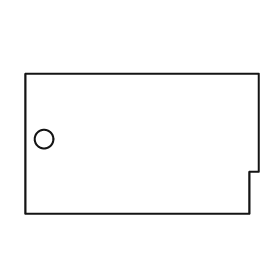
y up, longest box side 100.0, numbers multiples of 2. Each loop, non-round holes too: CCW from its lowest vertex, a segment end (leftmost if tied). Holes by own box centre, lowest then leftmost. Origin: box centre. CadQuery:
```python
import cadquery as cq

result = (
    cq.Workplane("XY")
    .moveTo(-50.0, -30.0)
    .lineTo(46.0, -30.0)
    .lineTo(46.0, -12.0)
    .lineTo(50.0, -12.0)
    .lineTo(50.0, 30.0)
    .lineTo(-50.0, 30.0)
    .close()
    .moveTo(-42.0, 2.0)
    .circle(4.0)
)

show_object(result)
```